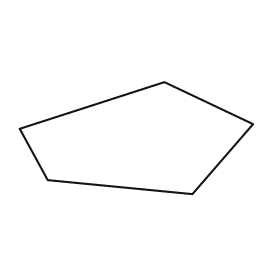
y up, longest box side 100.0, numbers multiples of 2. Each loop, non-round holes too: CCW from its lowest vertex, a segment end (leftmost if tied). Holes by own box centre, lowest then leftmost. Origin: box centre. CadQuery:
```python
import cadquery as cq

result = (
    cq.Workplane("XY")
    .moveTo(24.0, -24.0)
    .lineTo(50.0, 6.0)
    .lineTo(12.0, 24.0)
    .lineTo(-50.0, 4.0)
    .lineTo(-38.0, -18.0)
    .close()
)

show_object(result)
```